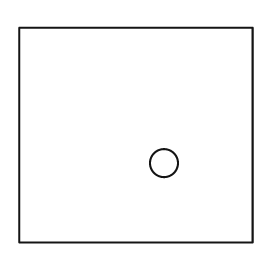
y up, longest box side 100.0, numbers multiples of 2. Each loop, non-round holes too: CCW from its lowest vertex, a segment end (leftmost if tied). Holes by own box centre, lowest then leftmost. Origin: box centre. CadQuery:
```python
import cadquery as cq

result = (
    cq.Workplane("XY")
    .moveTo(-50.0, -46.0)
    .lineTo(50.0, -46.0)
    .lineTo(50.0, 46.0)
    .lineTo(-50.0, 46.0)
    .close()
    .moveTo(12.0, -12.0)
    .circle(6.0)
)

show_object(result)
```